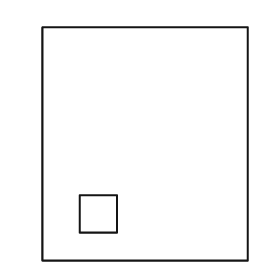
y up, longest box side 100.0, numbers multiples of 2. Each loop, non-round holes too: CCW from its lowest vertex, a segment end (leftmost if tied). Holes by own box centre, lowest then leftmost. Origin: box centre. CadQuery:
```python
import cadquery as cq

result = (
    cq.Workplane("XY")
    .moveTo(-44.0, -50.0)
    .lineTo(44.0, -50.0)
    .lineTo(44.0, 50.0)
    .lineTo(-44.0, 50.0)
    .close()
    .moveTo(-28.0, -38.0)
    .lineTo(-12.0, -38.0)
    .lineTo(-12.0, -22.0)
    .lineTo(-28.0, -22.0)
    .close()
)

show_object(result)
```